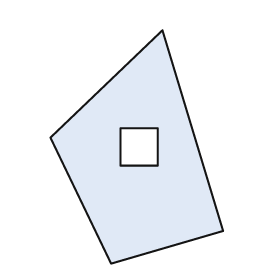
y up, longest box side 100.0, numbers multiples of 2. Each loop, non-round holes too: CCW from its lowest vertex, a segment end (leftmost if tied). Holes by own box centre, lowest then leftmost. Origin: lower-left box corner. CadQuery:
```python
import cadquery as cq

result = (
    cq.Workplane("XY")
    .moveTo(26.0, 0.0)
    .lineTo(74.0, 14.0)
    .lineTo(48.0, 100.0)
    .lineTo(0.0, 54.0)
    .close()
    .moveTo(30.0, 42.0)
    .lineTo(46.0, 42.0)
    .lineTo(46.0, 58.0)
    .lineTo(30.0, 58.0)
    .close()
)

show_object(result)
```